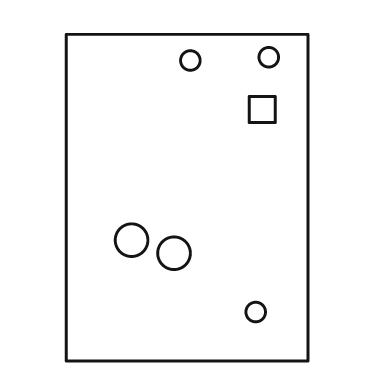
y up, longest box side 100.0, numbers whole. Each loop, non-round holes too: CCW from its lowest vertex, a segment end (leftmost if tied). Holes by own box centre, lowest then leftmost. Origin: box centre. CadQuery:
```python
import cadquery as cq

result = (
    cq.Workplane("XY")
    .moveTo(-37.0, -50.0)
    .lineTo(37.0, -50.0)
    .lineTo(37.0, 50.0)
    .lineTo(-37.0, 50.0)
    .close()
    .moveTo(21.0, -35.0)
    .circle(3.0)
    .moveTo(-4.0, -17.0)
    .circle(5.0)
    .moveTo(-17.0, -13.0)
    .circle(5.0)
    .moveTo(19.0, 23.0)
    .lineTo(27.0, 23.0)
    .lineTo(27.0, 31.0)
    .lineTo(19.0, 31.0)
    .close()
    .moveTo(1.0, 42.0)
    .circle(3.0)
    .moveTo(25.0, 43.0)
    .circle(3.0)
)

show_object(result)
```